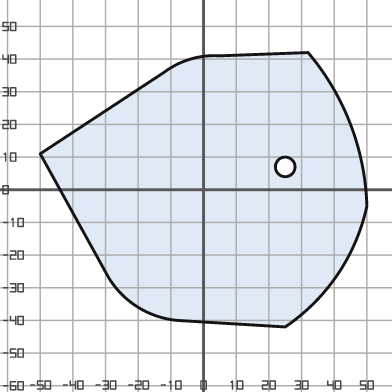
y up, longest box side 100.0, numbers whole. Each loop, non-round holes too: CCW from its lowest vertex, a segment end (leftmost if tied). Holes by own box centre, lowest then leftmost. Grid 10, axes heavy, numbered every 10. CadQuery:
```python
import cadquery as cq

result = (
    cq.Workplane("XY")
    .moveTo(25.0, -42.0)
    .threePointArc((41.0, -26.0), (50.0, -5.0))
    .threePointArc((45.0, 20.0), (32.0, 42.0))
    .lineTo(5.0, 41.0)
    .threePointArc((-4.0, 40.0), (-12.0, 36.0))
    .lineTo(-50.0, 11.0)
    .lineTo(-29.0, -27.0)
    .threePointArc((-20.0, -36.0), (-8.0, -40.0))
    .close()
    .moveTo(25.0, 7.0)
    .circle(3.0)
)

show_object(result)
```